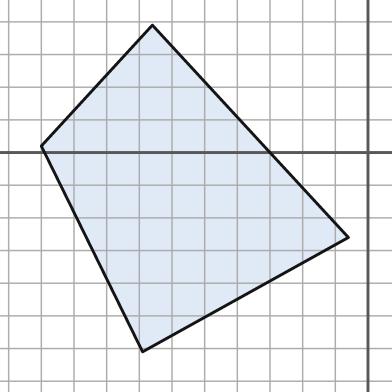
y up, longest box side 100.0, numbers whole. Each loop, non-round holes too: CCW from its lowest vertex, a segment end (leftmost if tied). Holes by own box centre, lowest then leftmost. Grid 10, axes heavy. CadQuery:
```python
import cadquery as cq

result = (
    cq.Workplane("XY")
    .moveTo(-69.0, -61.0)
    .lineTo(-6.0, -26.0)
    .lineTo(-66.0, 39.0)
    .lineTo(-100.0, 2.0)
    .close()
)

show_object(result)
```